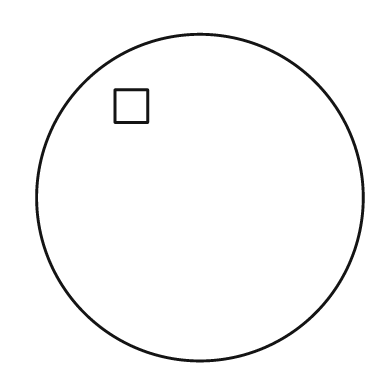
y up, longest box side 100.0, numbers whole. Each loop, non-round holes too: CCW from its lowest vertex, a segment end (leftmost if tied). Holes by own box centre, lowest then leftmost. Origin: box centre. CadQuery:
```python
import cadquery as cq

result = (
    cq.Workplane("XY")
    .moveTo(0.0, 0.0)
    .circle(50.0)
    .moveTo(-26.0, 23.0)
    .lineTo(-16.0, 23.0)
    .lineTo(-16.0, 33.0)
    .lineTo(-26.0, 33.0)
    .close()
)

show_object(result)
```